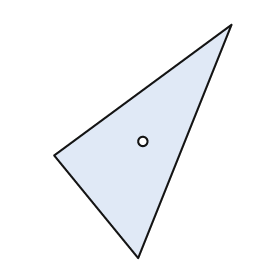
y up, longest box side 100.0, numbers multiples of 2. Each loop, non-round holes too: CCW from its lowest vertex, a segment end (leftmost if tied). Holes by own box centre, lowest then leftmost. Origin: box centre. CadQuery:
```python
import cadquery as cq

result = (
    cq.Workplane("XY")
    .moveTo(-2.0, -50.0)
    .lineTo(38.0, 50.0)
    .lineTo(-38.0, -6.0)
    .close()
    .moveTo(0.0, 0.0)
    .circle(2.0)
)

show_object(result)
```